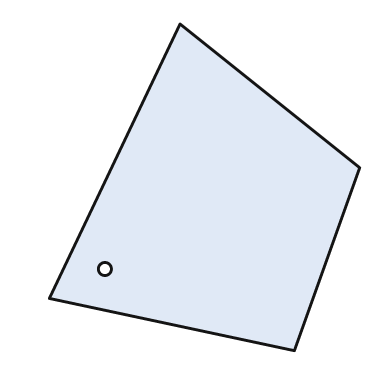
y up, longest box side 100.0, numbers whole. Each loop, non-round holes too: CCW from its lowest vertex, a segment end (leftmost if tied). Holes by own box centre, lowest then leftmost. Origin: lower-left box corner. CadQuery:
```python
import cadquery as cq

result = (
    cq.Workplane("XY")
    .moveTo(75.0, 0.0)
    .lineTo(95.0, 56.0)
    .lineTo(40.0, 100.0)
    .lineTo(0.0, 16.0)
    .close()
    .moveTo(17.0, 25.0)
    .circle(2.0)
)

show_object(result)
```